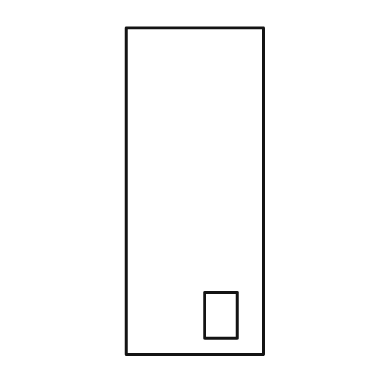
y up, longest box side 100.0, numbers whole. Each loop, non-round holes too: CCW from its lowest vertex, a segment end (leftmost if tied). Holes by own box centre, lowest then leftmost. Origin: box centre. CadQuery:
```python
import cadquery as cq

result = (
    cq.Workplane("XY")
    .moveTo(-21.0, -50.0)
    .lineTo(21.0, -50.0)
    .lineTo(21.0, 50.0)
    .lineTo(-21.0, 50.0)
    .close()
    .moveTo(3.0, -45.0)
    .lineTo(13.0, -45.0)
    .lineTo(13.0, -31.0)
    .lineTo(3.0, -31.0)
    .close()
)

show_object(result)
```